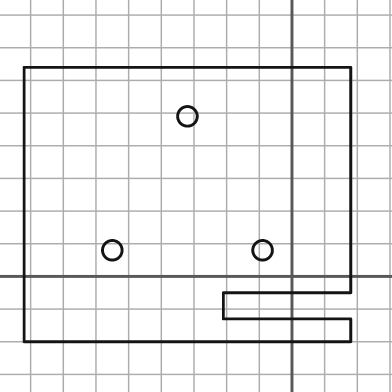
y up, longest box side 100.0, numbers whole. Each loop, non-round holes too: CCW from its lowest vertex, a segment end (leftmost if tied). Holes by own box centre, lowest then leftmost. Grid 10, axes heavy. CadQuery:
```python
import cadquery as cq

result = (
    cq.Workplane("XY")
    .moveTo(-82.0, -20.0)
    .lineTo(18.0, -20.0)
    .lineTo(18.0, -13.0)
    .lineTo(-21.0, -13.0)
    .lineTo(-21.0, -5.0)
    .lineTo(18.0, -5.0)
    .lineTo(18.0, 64.0)
    .lineTo(-82.0, 64.0)
    .close()
    .moveTo(-55.0, 8.0)
    .circle(3.0)
    .moveTo(-9.0, 8.0)
    .circle(3.0)
    .moveTo(-32.0, 49.0)
    .circle(3.0)
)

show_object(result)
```